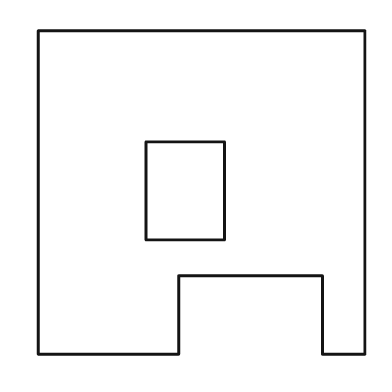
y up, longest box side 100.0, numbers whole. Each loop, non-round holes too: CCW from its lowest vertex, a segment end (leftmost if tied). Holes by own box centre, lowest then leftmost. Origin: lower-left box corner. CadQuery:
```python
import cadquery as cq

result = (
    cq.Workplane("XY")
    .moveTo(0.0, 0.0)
    .lineTo(43.0, 0.0)
    .lineTo(43.0, 24.0)
    .lineTo(87.0, 24.0)
    .lineTo(87.0, 0.0)
    .lineTo(100.0, 0.0)
    .lineTo(100.0, 99.0)
    .lineTo(0.0, 99.0)
    .close()
    .moveTo(33.0, 35.0)
    .lineTo(57.0, 35.0)
    .lineTo(57.0, 65.0)
    .lineTo(33.0, 65.0)
    .close()
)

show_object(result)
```